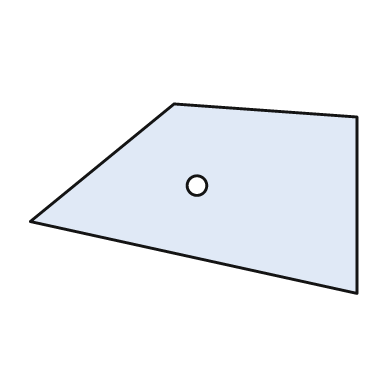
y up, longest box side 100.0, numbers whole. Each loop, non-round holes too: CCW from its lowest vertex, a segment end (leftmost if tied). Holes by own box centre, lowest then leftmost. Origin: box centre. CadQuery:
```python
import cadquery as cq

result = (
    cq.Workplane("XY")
    .moveTo(50.0, -29.0)
    .lineTo(50.0, 25.0)
    .lineTo(-6.0, 29.0)
    .lineTo(-50.0, -7.0)
    .close()
    .moveTo(1.0, 4.0)
    .circle(3.0)
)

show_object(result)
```